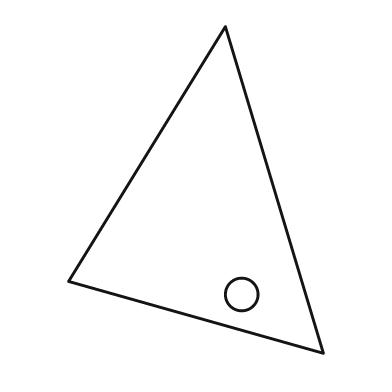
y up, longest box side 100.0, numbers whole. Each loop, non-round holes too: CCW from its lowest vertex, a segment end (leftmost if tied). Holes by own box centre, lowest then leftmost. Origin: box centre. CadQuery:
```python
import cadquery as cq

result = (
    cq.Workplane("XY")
    .moveTo(39.0, -50.0)
    .lineTo(9.0, 50.0)
    .lineTo(-39.0, -28.0)
    .close()
    .moveTo(14.0, -32.0)
    .circle(5.0)
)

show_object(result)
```